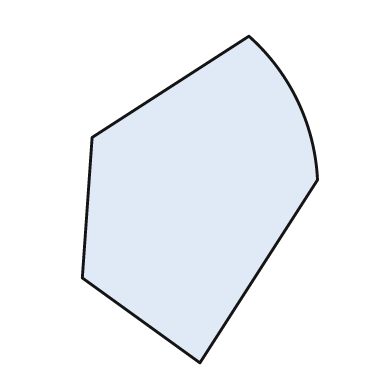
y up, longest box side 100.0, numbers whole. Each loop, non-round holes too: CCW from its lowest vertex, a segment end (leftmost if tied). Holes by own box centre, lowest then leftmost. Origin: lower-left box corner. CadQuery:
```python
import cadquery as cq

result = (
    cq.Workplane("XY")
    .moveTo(36.0, 0.0)
    .lineTo(72.0, 56.0)
    .threePointArc((66.0, 80.0), (51.0, 100.0))
    .lineTo(3.0, 69.0)
    .lineTo(0.0, 26.0)
    .close()
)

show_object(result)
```